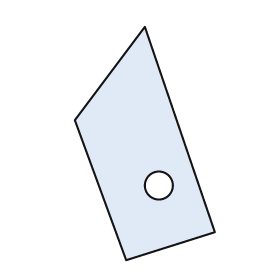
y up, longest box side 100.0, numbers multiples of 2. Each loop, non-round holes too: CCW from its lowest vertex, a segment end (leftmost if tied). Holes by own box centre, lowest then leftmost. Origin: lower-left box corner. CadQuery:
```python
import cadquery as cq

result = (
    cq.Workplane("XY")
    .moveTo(22.0, 0.0)
    .lineTo(60.0, 12.0)
    .lineTo(30.0, 100.0)
    .lineTo(0.0, 60.0)
    .close()
    .moveTo(36.0, 32.0)
    .circle(6.0)
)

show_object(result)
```